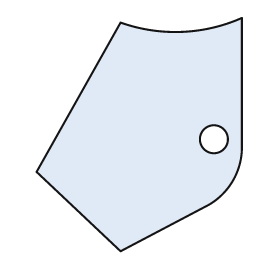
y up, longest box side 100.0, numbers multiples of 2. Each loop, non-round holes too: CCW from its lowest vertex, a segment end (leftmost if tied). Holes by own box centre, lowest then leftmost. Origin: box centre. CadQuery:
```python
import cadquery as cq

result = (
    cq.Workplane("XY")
    .moveTo(-8.0, -50.0)
    .lineTo(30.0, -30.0)
    .threePointArc((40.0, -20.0), (44.0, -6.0))
    .lineTo(44.0, 50.0)
    .threePointArc((18.0, 44.0), (-8.0, 48.0))
    .lineTo(-44.0, -16.0)
    .close()
    .moveTo(32.0, -2.0)
    .circle(6.0)
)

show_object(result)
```